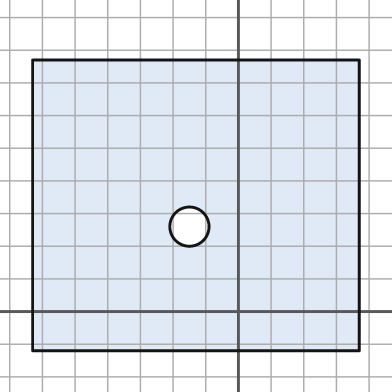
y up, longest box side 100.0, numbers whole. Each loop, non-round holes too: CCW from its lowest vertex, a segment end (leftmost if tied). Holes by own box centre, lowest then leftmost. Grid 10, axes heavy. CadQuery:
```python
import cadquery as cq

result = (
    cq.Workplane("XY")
    .moveTo(-63.0, -12.0)
    .lineTo(37.0, -12.0)
    .lineTo(37.0, 77.0)
    .lineTo(-63.0, 77.0)
    .close()
    .moveTo(-15.0, 26.0)
    .circle(6.0)
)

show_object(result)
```